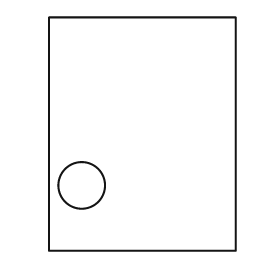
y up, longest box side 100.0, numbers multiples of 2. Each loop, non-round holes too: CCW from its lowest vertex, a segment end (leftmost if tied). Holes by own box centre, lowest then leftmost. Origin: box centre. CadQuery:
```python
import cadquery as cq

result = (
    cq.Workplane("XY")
    .moveTo(-40.0, -50.0)
    .lineTo(40.0, -50.0)
    .lineTo(40.0, 50.0)
    .lineTo(-40.0, 50.0)
    .close()
    .moveTo(-26.0, -22.0)
    .circle(10.0)
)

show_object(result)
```